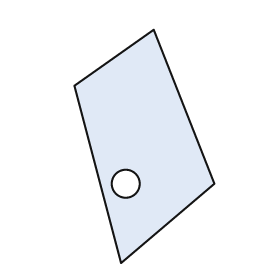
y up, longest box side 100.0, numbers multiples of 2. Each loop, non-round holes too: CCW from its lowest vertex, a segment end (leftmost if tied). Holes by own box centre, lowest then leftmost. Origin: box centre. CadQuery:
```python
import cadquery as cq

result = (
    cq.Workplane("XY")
    .moveTo(-10.0, -50.0)
    .lineTo(30.0, -16.0)
    .lineTo(4.0, 50.0)
    .lineTo(-30.0, 26.0)
    .close()
    .moveTo(-8.0, -16.0)
    .circle(6.0)
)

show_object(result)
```